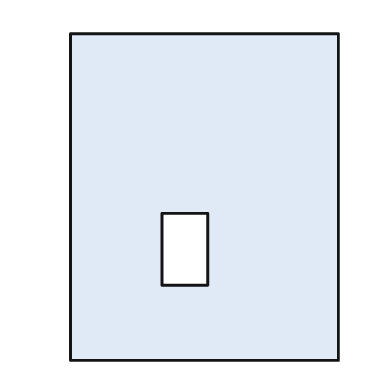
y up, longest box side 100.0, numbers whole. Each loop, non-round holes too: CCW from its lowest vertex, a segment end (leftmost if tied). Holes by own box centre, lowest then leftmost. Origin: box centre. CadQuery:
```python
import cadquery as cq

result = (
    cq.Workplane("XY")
    .moveTo(-41.0, -50.0)
    .lineTo(41.0, -50.0)
    .lineTo(41.0, 50.0)
    .lineTo(-41.0, 50.0)
    .close()
    .moveTo(-13.0, -27.0)
    .lineTo(1.0, -27.0)
    .lineTo(1.0, -5.0)
    .lineTo(-13.0, -5.0)
    .close()
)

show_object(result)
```